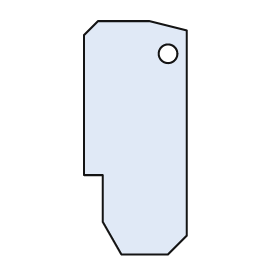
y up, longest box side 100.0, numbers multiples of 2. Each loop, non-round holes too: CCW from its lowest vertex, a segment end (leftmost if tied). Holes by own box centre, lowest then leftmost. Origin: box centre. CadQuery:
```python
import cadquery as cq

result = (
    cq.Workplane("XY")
    .moveTo(-6.0, -50.0)
    .lineTo(14.0, -50.0)
    .lineTo(22.0, -42.0)
    .lineTo(22.0, 46.0)
    .lineTo(6.0, 50.0)
    .lineTo(-16.0, 50.0)
    .lineTo(-22.0, 44.0)
    .lineTo(-22.0, -16.0)
    .lineTo(-14.0, -16.0)
    .lineTo(-14.0, -36.0)
    .close()
    .moveTo(14.0, 36.0)
    .circle(4.0)
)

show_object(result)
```